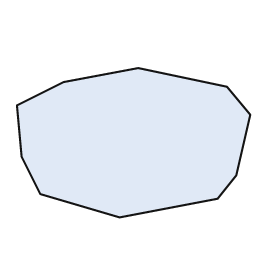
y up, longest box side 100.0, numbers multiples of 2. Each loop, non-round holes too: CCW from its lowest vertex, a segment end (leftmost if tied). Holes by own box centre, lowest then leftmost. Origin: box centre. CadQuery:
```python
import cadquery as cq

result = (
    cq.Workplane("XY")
    .moveTo(-6.0, -32.0)
    .lineTo(36.0, -24.0)
    .lineTo(44.0, -14.0)
    .lineTo(50.0, 12.0)
    .lineTo(40.0, 24.0)
    .lineTo(2.0, 32.0)
    .lineTo(-30.0, 26.0)
    .lineTo(-50.0, 16.0)
    .lineTo(-48.0, -6.0)
    .lineTo(-40.0, -22.0)
    .close()
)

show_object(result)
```